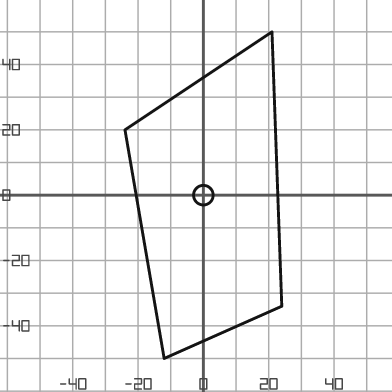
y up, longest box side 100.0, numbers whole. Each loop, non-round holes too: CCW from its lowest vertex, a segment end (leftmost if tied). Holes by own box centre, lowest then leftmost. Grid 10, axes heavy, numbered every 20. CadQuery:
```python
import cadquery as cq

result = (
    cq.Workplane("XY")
    .moveTo(-12.0, -50.0)
    .lineTo(24.0, -34.0)
    .lineTo(21.0, 50.0)
    .lineTo(-24.0, 20.0)
    .close()
    .moveTo(0.0, 0.0)
    .circle(3.0)
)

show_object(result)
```